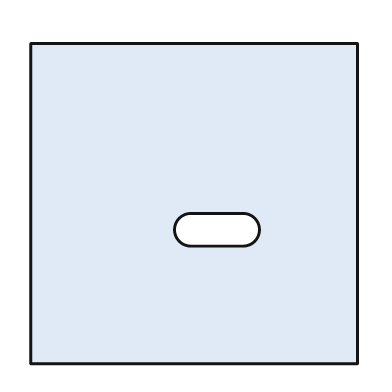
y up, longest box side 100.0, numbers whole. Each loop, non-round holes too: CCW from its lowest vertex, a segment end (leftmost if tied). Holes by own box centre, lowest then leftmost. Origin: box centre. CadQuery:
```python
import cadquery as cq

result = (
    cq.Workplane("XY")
    .moveTo(-50.0, -49.0)
    .lineTo(50.0, -49.0)
    .lineTo(50.0, 49.0)
    .lineTo(-50.0, 49.0)
    .close()
    .moveTo(-1.0, -13.0)
    .lineTo(15.0, -13.0)
    .threePointArc((20.0, -8.0), (15.0, -3.0))
    .lineTo(-1.0, -3.0)
    .threePointArc((-6.0, -8.0), (-1.0, -13.0))
    .close()
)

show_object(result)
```